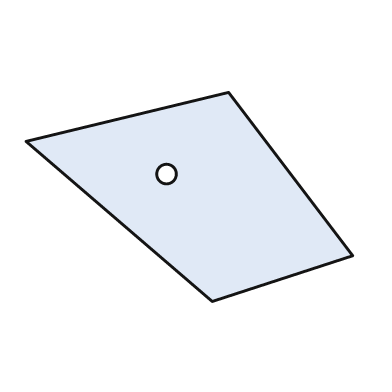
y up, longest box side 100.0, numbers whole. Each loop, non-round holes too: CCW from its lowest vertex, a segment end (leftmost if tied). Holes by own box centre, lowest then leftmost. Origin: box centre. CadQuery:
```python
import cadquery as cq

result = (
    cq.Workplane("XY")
    .moveTo(7.0, -32.0)
    .lineTo(50.0, -18.0)
    .lineTo(12.0, 32.0)
    .lineTo(-50.0, 17.0)
    .close()
    .moveTo(-7.0, 7.0)
    .circle(3.0)
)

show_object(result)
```